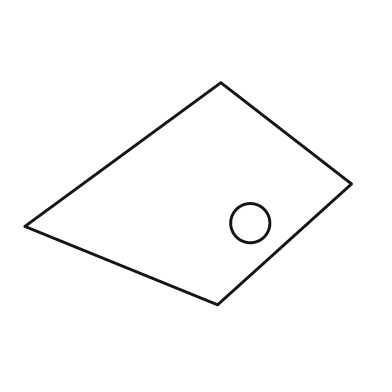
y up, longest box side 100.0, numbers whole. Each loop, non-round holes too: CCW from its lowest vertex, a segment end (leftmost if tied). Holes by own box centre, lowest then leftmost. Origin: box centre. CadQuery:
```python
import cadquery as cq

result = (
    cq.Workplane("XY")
    .moveTo(9.0, -34.0)
    .lineTo(50.0, 3.0)
    .lineTo(10.0, 34.0)
    .lineTo(-50.0, -10.0)
    .close()
    .moveTo(19.0, -9.0)
    .circle(6.0)
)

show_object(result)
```